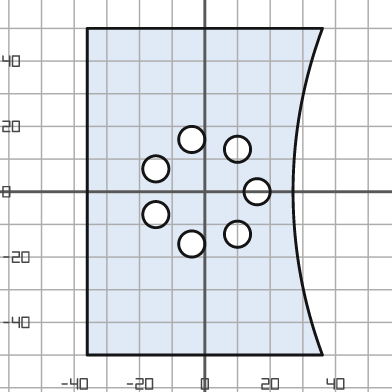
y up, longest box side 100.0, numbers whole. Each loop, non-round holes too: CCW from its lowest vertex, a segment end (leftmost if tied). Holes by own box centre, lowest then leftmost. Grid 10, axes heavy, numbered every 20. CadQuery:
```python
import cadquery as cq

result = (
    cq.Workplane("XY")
    .moveTo(-36.0, -50.0)
    .lineTo(36.0, -50.0)
    .threePointArc((27.0, 0.0), (36.0, 50.0))
    .lineTo(-36.0, 50.0)
    .close()
    .moveTo(-4.0, -16.0)
    .circle(4.0)
    .moveTo(10.0, -13.0)
    .circle(4.0)
    .moveTo(-15.0, -7.0)
    .circle(4.0)
    .moveTo(16.0, 0.0)
    .circle(4.0)
    .moveTo(-15.0, 7.0)
    .circle(4.0)
    .moveTo(10.0, 13.0)
    .circle(4.0)
    .moveTo(-4.0, 16.0)
    .circle(4.0)
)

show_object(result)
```